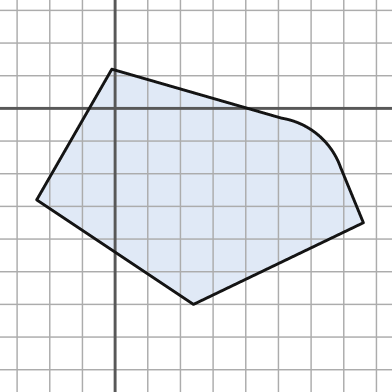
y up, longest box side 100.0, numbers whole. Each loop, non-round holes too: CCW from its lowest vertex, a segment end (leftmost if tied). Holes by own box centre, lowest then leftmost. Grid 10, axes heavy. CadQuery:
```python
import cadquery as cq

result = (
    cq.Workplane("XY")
    .moveTo(24.0, -60.0)
    .lineTo(76.0, -35.0)
    .lineTo(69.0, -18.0)
    .threePointArc((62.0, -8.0), (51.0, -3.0))
    .lineTo(-1.0, 12.0)
    .lineTo(-24.0, -28.0)
    .close()
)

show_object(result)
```